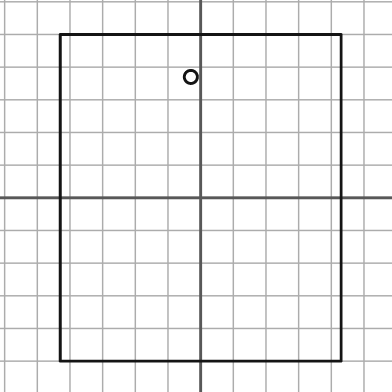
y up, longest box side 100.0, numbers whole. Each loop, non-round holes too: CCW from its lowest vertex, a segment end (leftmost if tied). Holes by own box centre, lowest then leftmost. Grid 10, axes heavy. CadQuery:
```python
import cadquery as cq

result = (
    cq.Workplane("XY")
    .moveTo(-43.0, -50.0)
    .lineTo(43.0, -50.0)
    .lineTo(43.0, 50.0)
    .lineTo(-43.0, 50.0)
    .close()
    .moveTo(-3.0, 37.0)
    .circle(2.0)
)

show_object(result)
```